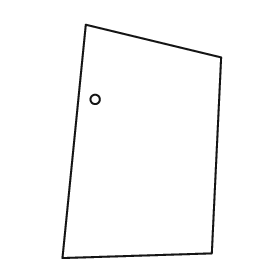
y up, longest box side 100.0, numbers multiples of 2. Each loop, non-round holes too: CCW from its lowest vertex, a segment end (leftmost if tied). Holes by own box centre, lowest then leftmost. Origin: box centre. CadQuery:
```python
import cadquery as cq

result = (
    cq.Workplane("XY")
    .moveTo(-34.0, -50.0)
    .lineTo(30.0, -48.0)
    .lineTo(34.0, 36.0)
    .lineTo(-24.0, 50.0)
    .close()
    .moveTo(-20.0, 18.0)
    .circle(2.0)
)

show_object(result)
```